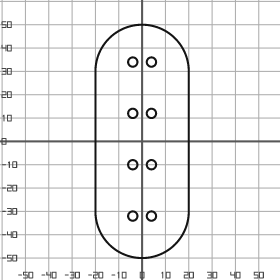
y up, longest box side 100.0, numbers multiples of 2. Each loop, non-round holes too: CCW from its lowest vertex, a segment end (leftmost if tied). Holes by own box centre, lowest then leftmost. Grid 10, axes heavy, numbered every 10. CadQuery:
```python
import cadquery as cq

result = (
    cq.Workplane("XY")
    .moveTo(-20.0, -30.0)
    .threePointArc((0.0, -50.0), (20.0, -30.0))
    .lineTo(20.0, 30.0)
    .threePointArc((0.0, 50.0), (-20.0, 30.0))
    .close()
    .moveTo(-4.0, -32.0)
    .circle(2.0)
    .moveTo(4.0, -32.0)
    .circle(2.0)
    .moveTo(-4.0, -10.0)
    .circle(2.0)
    .moveTo(4.0, -10.0)
    .circle(2.0)
    .moveTo(-4.0, 12.0)
    .circle(2.0)
    .moveTo(4.0, 12.0)
    .circle(2.0)
    .moveTo(-4.0, 34.0)
    .circle(2.0)
    .moveTo(4.0, 34.0)
    .circle(2.0)
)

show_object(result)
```